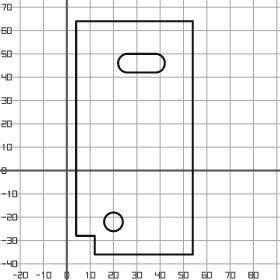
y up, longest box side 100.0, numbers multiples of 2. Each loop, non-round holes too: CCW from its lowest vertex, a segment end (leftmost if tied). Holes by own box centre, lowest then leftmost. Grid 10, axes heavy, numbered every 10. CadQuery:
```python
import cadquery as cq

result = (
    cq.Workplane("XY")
    .moveTo(12.0, -36.0)
    .lineTo(54.0, -36.0)
    .lineTo(54.0, 64.0)
    .lineTo(4.0, 64.0)
    .lineTo(4.0, -28.0)
    .lineTo(12.0, -28.0)
    .close()
    .moveTo(20.0, -22.0)
    .circle(4.0)
    .moveTo(26.0, 42.0)
    .lineTo(38.0, 42.0)
    .threePointArc((42.0, 46.0), (38.0, 50.0))
    .lineTo(26.0, 50.0)
    .threePointArc((22.0, 46.0), (26.0, 42.0))
    .close()
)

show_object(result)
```